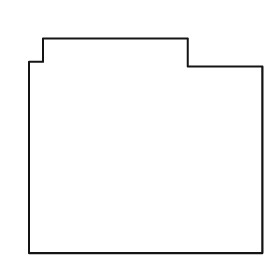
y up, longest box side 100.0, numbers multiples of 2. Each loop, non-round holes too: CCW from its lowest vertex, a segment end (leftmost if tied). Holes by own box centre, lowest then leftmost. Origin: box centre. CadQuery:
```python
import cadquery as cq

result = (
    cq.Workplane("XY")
    .moveTo(-50.0, -46.0)
    .lineTo(50.0, -46.0)
    .lineTo(50.0, 34.0)
    .lineTo(18.0, 34.0)
    .lineTo(18.0, 46.0)
    .lineTo(-44.0, 46.0)
    .lineTo(-44.0, 36.0)
    .lineTo(-50.0, 36.0)
    .close()
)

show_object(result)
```